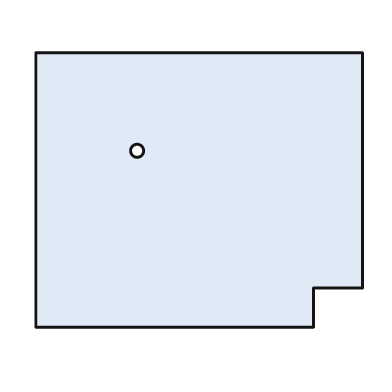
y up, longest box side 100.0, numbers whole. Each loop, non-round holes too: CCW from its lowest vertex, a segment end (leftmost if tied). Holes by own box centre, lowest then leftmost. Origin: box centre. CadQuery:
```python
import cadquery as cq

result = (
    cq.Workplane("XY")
    .moveTo(-50.0, -42.0)
    .lineTo(35.0, -42.0)
    .lineTo(35.0, -30.0)
    .lineTo(50.0, -30.0)
    .lineTo(50.0, 42.0)
    .lineTo(-50.0, 42.0)
    .close()
    .moveTo(-19.0, 12.0)
    .circle(2.0)
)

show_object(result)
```